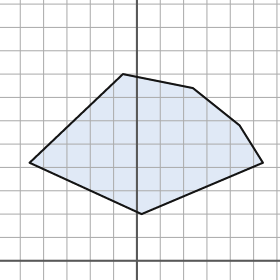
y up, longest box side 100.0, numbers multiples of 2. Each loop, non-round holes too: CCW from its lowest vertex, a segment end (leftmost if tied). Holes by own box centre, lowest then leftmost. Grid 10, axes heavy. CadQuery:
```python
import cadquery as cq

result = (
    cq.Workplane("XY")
    .moveTo(2.0, 20.0)
    .lineTo(54.0, 42.0)
    .lineTo(44.0, 58.0)
    .lineTo(24.0, 74.0)
    .lineTo(-6.0, 80.0)
    .lineTo(-46.0, 42.0)
    .close()
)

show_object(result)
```